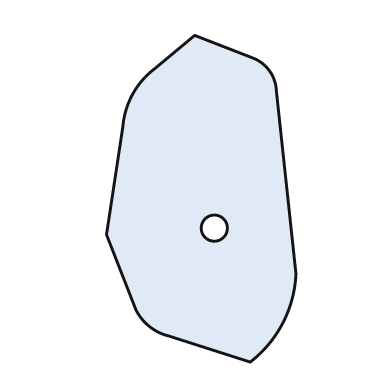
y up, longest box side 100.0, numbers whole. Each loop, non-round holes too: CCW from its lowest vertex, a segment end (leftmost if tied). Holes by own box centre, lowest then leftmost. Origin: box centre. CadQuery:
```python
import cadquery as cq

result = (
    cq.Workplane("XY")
    .moveTo(15.0, -50.0)
    .threePointArc((25.0, -38.0), (29.0, -23.0))
    .lineTo(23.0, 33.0)
    .threePointArc((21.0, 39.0), (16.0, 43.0))
    .lineTo(-2.0, 50.0)
    .lineTo(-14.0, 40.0)
    .threePointArc((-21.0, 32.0), (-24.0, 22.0))
    .lineTo(-29.0, -11.0)
    .lineTo(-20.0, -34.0)
    .threePointArc((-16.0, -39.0), (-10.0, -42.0))
    .close()
    .moveTo(4.0, -9.0)
    .circle(4.0)
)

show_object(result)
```